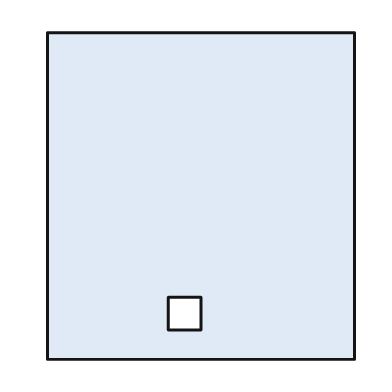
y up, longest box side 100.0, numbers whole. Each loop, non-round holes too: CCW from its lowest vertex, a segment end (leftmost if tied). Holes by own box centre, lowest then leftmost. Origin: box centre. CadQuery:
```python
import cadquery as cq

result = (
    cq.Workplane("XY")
    .moveTo(-47.0, -50.0)
    .lineTo(47.0, -50.0)
    .lineTo(47.0, 50.0)
    .lineTo(-47.0, 50.0)
    .close()
    .moveTo(-10.0, -41.0)
    .lineTo(0.0, -41.0)
    .lineTo(0.0, -31.0)
    .lineTo(-10.0, -31.0)
    .close()
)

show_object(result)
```